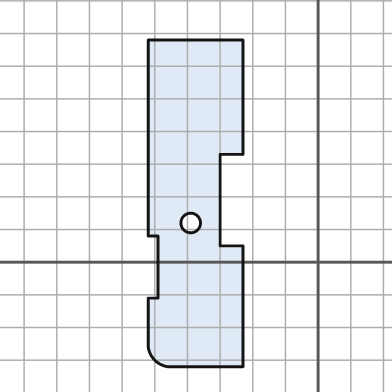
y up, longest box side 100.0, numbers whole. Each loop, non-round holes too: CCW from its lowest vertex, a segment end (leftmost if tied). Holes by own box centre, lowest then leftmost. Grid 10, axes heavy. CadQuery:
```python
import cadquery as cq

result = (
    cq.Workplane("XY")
    .moveTo(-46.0, -32.0)
    .lineTo(-23.0, -32.0)
    .lineTo(-23.0, 5.0)
    .lineTo(-30.0, 5.0)
    .lineTo(-30.0, 33.0)
    .lineTo(-23.0, 33.0)
    .lineTo(-23.0, 68.0)
    .lineTo(-52.0, 68.0)
    .lineTo(-52.0, 8.0)
    .lineTo(-49.0, 8.0)
    .lineTo(-49.0, -11.0)
    .lineTo(-52.0, -11.0)
    .lineTo(-52.0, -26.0)
    .threePointArc((-50.0, -30.0), (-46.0, -32.0))
    .close()
    .moveTo(-39.0, 12.0)
    .circle(3.0)
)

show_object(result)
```